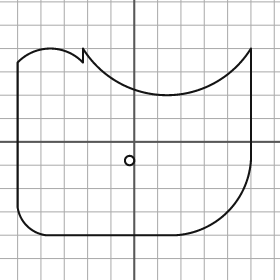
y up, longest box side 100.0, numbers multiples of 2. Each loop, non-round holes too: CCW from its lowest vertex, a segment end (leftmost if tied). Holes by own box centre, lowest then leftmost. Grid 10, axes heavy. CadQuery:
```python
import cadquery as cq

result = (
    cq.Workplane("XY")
    .moveTo(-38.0, -40.0)
    .lineTo(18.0, -40.0)
    .threePointArc((40.0, -30.0), (50.0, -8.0))
    .lineTo(50.0, 40.0)
    .threePointArc((14.0, 20.0), (-22.0, 40.0))
    .lineTo(-22.0, 34.0)
    .threePointArc((-36.0, 40.0), (-50.0, 34.0))
    .lineTo(-50.0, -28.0)
    .threePointArc((-46.0, -36.0), (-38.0, -40.0))
    .close()
    .moveTo(-2.0, -8.0)
    .circle(2.0)
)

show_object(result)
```